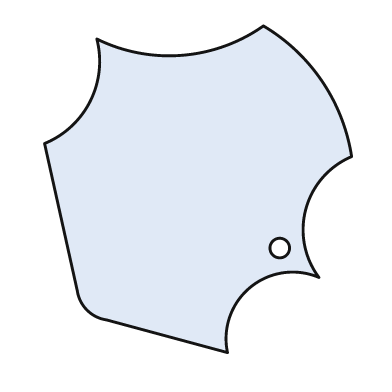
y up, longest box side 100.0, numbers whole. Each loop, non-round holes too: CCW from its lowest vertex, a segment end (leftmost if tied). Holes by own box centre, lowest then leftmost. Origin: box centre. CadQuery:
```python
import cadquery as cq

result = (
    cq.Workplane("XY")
    .moveTo(9.0, -50.0)
    .threePointArc((16.0, -30.0), (37.0, -27.0))
    .threePointArc((33.0, -6.0), (47.0, 10.0))
    .threePointArc((38.0, 33.0), (20.0, 50.0))
    .threePointArc((-5.0, 41.0), (-31.0, 46.0))
    .threePointArc((-33.0, 27.0), (-47.0, 14.0))
    .lineTo(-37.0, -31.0)
    .threePointArc((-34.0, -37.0), (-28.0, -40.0))
    .close()
    .moveTo(25.0, -18.0)
    .circle(3.0)
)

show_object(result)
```